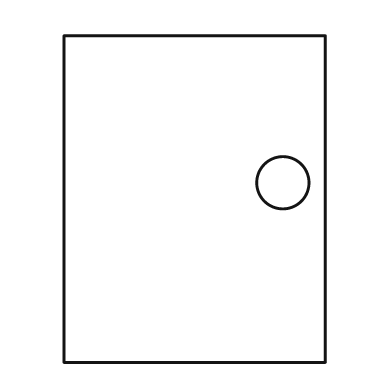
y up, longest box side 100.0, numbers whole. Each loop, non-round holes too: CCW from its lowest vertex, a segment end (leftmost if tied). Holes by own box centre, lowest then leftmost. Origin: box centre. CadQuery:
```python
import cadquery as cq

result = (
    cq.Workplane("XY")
    .moveTo(-40.0, -50.0)
    .lineTo(40.0, -50.0)
    .lineTo(40.0, 50.0)
    .lineTo(-40.0, 50.0)
    .close()
    .moveTo(27.0, 5.0)
    .circle(8.0)
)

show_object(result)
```